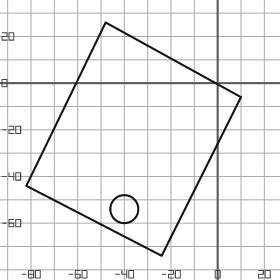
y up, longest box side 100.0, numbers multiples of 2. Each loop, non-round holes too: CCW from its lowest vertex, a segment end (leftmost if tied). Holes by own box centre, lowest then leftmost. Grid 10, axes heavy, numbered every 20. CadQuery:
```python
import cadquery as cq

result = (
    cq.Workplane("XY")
    .moveTo(-24.0, -74.0)
    .lineTo(10.0, -6.0)
    .lineTo(-48.0, 26.0)
    .lineTo(-82.0, -44.0)
    .close()
    .moveTo(-40.0, -54.0)
    .circle(6.0)
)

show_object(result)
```